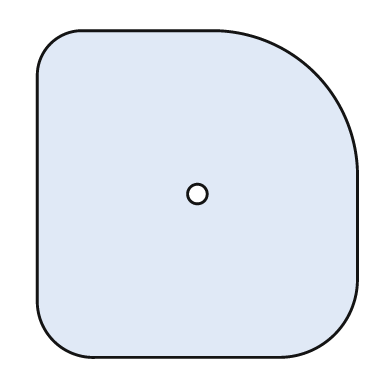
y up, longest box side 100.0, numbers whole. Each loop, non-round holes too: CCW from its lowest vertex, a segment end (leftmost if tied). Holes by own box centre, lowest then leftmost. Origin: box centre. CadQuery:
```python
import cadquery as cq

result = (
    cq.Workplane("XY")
    .moveTo(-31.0, -50.0)
    .lineTo(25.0, -50.0)
    .threePointArc((42.0, -43.0), (49.0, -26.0))
    .lineTo(49.0, 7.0)
    .threePointArc((36.0, 37.0), (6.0, 50.0))
    .lineTo(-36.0, 50.0)
    .threePointArc((-45.0, 46.0), (-49.0, 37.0))
    .lineTo(-49.0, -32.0)
    .threePointArc((-44.0, -45.0), (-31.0, -50.0))
    .close()
    .moveTo(0.0, 0.0)
    .circle(3.0)
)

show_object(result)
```